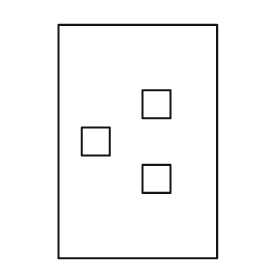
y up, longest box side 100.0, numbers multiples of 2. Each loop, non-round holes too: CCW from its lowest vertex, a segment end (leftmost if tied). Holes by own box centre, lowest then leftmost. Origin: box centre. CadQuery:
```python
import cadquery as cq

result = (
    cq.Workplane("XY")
    .moveTo(-34.0, -50.0)
    .lineTo(34.0, -50.0)
    .lineTo(34.0, 50.0)
    .lineTo(-34.0, 50.0)
    .close()
    .moveTo(2.0, -22.0)
    .lineTo(14.0, -22.0)
    .lineTo(14.0, -10.0)
    .lineTo(2.0, -10.0)
    .close()
    .moveTo(-24.0, -6.0)
    .lineTo(-12.0, -6.0)
    .lineTo(-12.0, 6.0)
    .lineTo(-24.0, 6.0)
    .close()
    .moveTo(2.0, 10.0)
    .lineTo(14.0, 10.0)
    .lineTo(14.0, 22.0)
    .lineTo(2.0, 22.0)
    .close()
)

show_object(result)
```